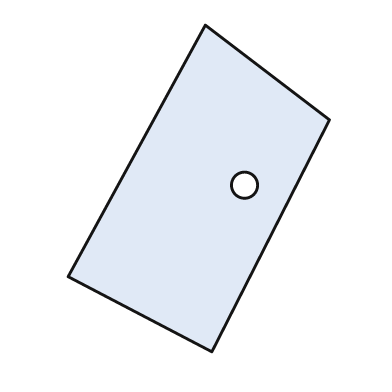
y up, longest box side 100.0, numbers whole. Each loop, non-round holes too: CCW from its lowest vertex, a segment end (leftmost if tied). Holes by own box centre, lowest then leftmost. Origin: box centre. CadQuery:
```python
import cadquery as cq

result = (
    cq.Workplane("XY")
    .moveTo(4.0, -50.0)
    .lineTo(40.0, 21.0)
    .lineTo(2.0, 50.0)
    .lineTo(-40.0, -27.0)
    .close()
    .moveTo(14.0, 1.0)
    .circle(4.0)
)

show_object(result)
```